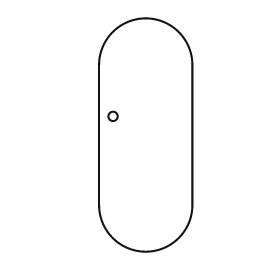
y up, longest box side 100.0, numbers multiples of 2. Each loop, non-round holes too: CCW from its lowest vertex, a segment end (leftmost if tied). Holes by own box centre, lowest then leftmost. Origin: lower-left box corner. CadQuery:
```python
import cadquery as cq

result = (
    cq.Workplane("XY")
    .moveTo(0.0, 20.0)
    .threePointArc((20.0, 0.0), (40.0, 20.0))
    .lineTo(40.0, 80.0)
    .threePointArc((20.0, 100.0), (0.0, 80.0))
    .close()
    .moveTo(6.0, 58.0)
    .circle(2.0)
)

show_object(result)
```